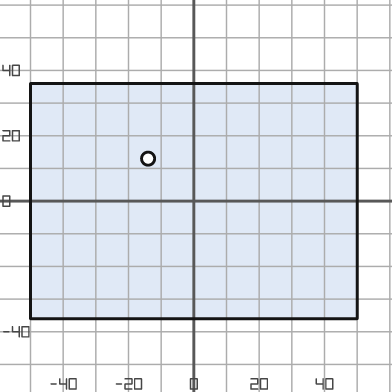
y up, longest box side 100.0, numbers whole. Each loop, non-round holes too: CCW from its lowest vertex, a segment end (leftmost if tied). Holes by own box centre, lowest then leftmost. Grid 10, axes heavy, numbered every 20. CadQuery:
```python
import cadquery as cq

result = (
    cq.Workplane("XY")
    .moveTo(-50.0, -36.0)
    .lineTo(50.0, -36.0)
    .lineTo(50.0, 36.0)
    .lineTo(-50.0, 36.0)
    .close()
    .moveTo(-14.0, 13.0)
    .circle(2.0)
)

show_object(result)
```